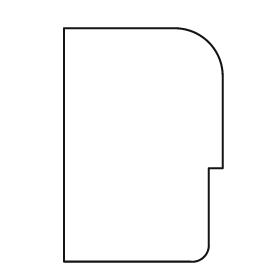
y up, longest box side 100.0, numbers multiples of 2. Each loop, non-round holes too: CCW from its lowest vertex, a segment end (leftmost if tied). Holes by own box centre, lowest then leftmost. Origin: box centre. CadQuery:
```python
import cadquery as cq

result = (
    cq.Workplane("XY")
    .moveTo(-34.0, -50.0)
    .lineTo(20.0, -50.0)
    .threePointArc((26.0, -48.0), (28.0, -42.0))
    .lineTo(28.0, -10.0)
    .lineTo(34.0, -10.0)
    .lineTo(34.0, 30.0)
    .threePointArc((28.0, 44.0), (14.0, 50.0))
    .lineTo(-34.0, 50.0)
    .close()
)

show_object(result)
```